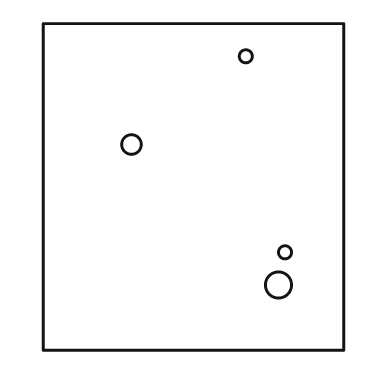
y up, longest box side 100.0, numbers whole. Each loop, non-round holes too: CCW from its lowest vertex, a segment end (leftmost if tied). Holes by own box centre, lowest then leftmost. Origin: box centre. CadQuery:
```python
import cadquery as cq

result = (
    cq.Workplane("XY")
    .moveTo(-46.0, -50.0)
    .lineTo(46.0, -50.0)
    .lineTo(46.0, 50.0)
    .lineTo(-46.0, 50.0)
    .close()
    .moveTo(26.0, -30.0)
    .circle(4.0)
    .moveTo(28.0, -20.0)
    .circle(2.0)
    .moveTo(-19.0, 13.0)
    .circle(3.0)
    .moveTo(16.0, 40.0)
    .circle(2.0)
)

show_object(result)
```